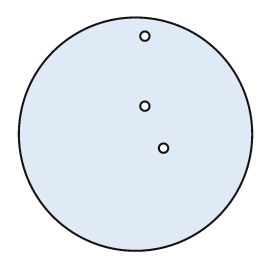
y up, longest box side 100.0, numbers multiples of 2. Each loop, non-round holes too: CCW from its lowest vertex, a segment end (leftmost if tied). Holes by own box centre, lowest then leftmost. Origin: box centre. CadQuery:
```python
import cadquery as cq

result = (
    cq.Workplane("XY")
    .moveTo(0.0, 0.0)
    .circle(50.0)
    .moveTo(12.0, -6.0)
    .circle(2.0)
    .moveTo(4.0, 12.0)
    .circle(2.0)
    .moveTo(4.0, 42.0)
    .circle(2.0)
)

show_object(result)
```